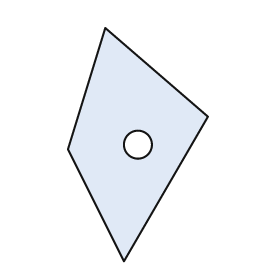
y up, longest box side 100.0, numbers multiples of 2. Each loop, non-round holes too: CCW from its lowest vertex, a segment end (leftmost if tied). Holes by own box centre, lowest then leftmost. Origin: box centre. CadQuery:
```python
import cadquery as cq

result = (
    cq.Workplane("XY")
    .moveTo(-6.0, -50.0)
    .lineTo(30.0, 12.0)
    .lineTo(-14.0, 50.0)
    .lineTo(-30.0, -2.0)
    .close()
    .moveTo(0.0, 0.0)
    .circle(6.0)
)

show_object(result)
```